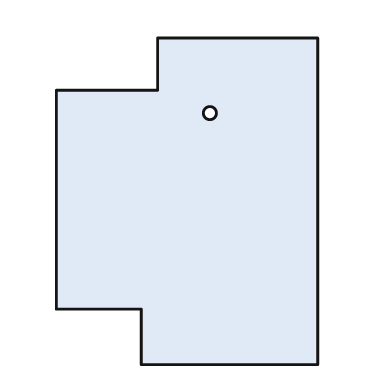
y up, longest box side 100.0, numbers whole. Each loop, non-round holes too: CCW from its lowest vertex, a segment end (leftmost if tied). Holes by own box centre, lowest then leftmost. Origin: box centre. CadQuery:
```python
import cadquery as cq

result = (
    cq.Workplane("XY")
    .moveTo(-14.0, -50.0)
    .lineTo(40.0, -50.0)
    .lineTo(40.0, 50.0)
    .lineTo(-9.0, 50.0)
    .lineTo(-9.0, 34.0)
    .lineTo(-40.0, 34.0)
    .lineTo(-40.0, -33.0)
    .lineTo(-14.0, -33.0)
    .close()
    .moveTo(7.0, 27.0)
    .circle(2.0)
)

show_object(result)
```